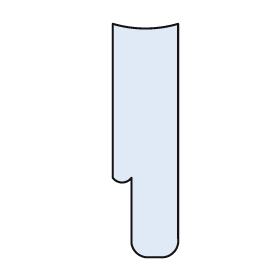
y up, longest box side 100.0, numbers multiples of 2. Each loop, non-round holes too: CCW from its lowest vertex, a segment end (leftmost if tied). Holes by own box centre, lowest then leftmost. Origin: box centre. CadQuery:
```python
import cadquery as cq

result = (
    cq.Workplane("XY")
    .moveTo(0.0, -50.0)
    .lineTo(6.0, -50.0)
    .threePointArc((12.0, -48.0), (14.0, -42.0))
    .lineTo(14.0, 50.0)
    .threePointArc((0.0, 48.0), (-14.0, 50.0))
    .lineTo(-14.0, -16.0)
    .threePointArc((-10.0, -18.0), (-6.0, -16.0))
    .lineTo(-6.0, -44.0)
    .threePointArc((-4.0, -48.0), (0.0, -50.0))
    .close()
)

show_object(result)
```